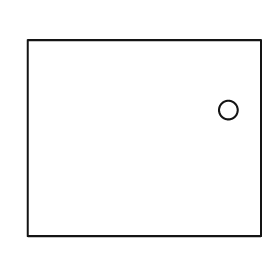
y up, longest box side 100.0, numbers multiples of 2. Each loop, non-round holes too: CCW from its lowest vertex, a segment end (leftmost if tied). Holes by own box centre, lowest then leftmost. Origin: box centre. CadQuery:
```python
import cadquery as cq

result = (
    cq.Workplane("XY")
    .moveTo(-50.0, -42.0)
    .lineTo(50.0, -42.0)
    .lineTo(50.0, 42.0)
    .lineTo(-50.0, 42.0)
    .close()
    .moveTo(36.0, 12.0)
    .circle(4.0)
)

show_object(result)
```